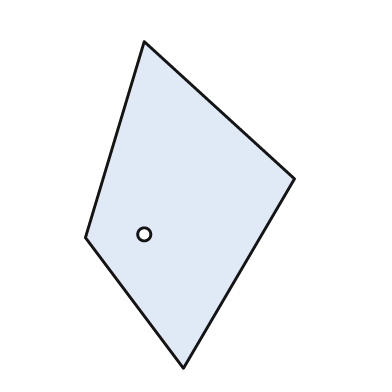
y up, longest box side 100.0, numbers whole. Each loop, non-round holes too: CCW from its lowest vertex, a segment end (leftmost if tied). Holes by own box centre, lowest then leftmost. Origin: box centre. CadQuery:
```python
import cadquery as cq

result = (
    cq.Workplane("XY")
    .moveTo(-2.0, -50.0)
    .lineTo(32.0, 8.0)
    .lineTo(-14.0, 50.0)
    .lineTo(-32.0, -10.0)
    .close()
    .moveTo(-14.0, -9.0)
    .circle(2.0)
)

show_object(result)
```